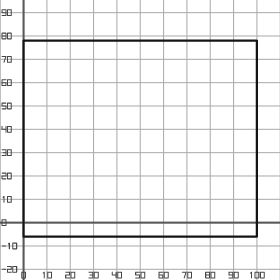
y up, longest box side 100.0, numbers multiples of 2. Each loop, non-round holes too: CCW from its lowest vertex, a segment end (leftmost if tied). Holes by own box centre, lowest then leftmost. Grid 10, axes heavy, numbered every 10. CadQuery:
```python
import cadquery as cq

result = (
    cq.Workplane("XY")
    .moveTo(0.0, -6.0)
    .lineTo(100.0, -6.0)
    .lineTo(100.0, 78.0)
    .lineTo(0.0, 78.0)
    .close()
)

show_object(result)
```